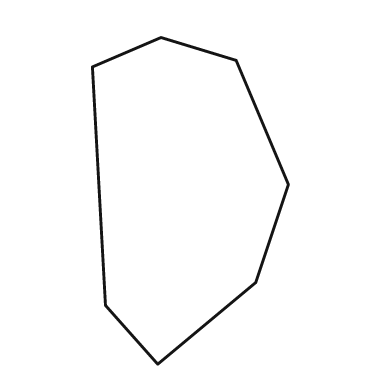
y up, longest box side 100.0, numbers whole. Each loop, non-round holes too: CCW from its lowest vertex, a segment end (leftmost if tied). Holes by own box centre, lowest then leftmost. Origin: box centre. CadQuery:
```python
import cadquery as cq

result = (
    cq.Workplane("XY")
    .moveTo(-10.0, -50.0)
    .lineTo(20.0, -25.0)
    .lineTo(30.0, 5.0)
    .lineTo(14.0, 43.0)
    .lineTo(-9.0, 50.0)
    .lineTo(-30.0, 41.0)
    .lineTo(-26.0, -32.0)
    .close()
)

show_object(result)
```